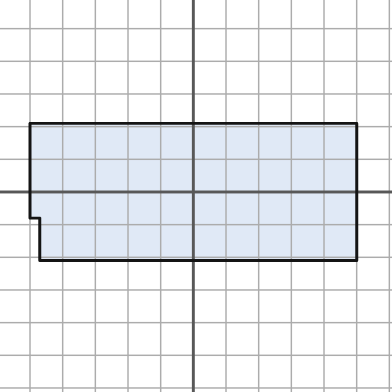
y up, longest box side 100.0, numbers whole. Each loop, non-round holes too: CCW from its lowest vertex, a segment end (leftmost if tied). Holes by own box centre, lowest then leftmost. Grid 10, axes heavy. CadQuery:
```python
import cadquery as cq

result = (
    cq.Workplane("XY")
    .moveTo(-47.0, -21.0)
    .lineTo(50.0, -21.0)
    .lineTo(50.0, 21.0)
    .lineTo(-50.0, 21.0)
    .lineTo(-50.0, -8.0)
    .lineTo(-47.0, -8.0)
    .close()
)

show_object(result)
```